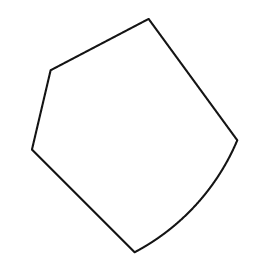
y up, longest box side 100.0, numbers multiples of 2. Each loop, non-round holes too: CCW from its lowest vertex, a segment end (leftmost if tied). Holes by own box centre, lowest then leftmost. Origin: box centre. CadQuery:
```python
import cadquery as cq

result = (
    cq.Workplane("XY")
    .moveTo(0.0, -50.0)
    .threePointArc((26.0, -30.0), (44.0, -2.0))
    .lineTo(6.0, 50.0)
    .lineTo(-36.0, 28.0)
    .lineTo(-44.0, -6.0)
    .close()
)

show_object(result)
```